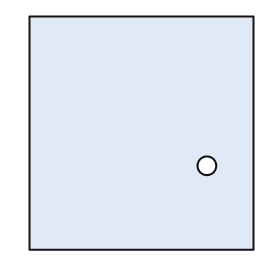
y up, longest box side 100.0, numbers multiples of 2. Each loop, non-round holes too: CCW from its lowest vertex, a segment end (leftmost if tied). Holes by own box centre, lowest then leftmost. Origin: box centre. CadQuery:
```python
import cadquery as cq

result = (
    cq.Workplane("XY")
    .moveTo(-48.0, -50.0)
    .lineTo(48.0, -50.0)
    .lineTo(48.0, 50.0)
    .lineTo(-48.0, 50.0)
    .close()
    .moveTo(28.0, -14.0)
    .circle(4.0)
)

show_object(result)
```